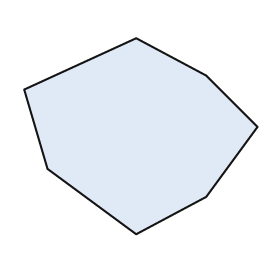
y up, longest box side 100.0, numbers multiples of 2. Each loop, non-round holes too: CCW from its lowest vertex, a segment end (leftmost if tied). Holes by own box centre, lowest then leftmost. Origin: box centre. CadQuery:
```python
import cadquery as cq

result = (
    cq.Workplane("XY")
    .moveTo(-2.0, -42.0)
    .lineTo(28.0, -26.0)
    .lineTo(50.0, 4.0)
    .lineTo(28.0, 26.0)
    .lineTo(-2.0, 42.0)
    .lineTo(-50.0, 20.0)
    .lineTo(-40.0, -14.0)
    .close()
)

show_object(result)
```